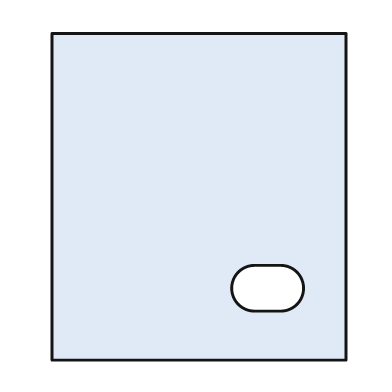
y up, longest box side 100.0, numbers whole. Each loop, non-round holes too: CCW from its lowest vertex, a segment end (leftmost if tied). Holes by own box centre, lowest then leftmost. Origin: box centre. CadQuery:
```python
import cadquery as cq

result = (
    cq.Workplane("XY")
    .moveTo(-45.0, -50.0)
    .lineTo(45.0, -50.0)
    .lineTo(45.0, 50.0)
    .lineTo(-45.0, 50.0)
    .close()
    .moveTo(17.0, -35.0)
    .lineTo(25.0, -35.0)
    .threePointArc((32.0, -28.0), (25.0, -21.0))
    .lineTo(17.0, -21.0)
    .threePointArc((10.0, -28.0), (17.0, -35.0))
    .close()
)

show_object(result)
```